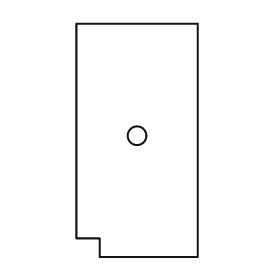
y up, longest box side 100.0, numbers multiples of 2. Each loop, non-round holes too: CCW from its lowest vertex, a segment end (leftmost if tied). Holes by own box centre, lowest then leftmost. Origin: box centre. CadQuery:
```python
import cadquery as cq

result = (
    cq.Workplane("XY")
    .moveTo(-16.0, -50.0)
    .lineTo(26.0, -50.0)
    .lineTo(26.0, 50.0)
    .lineTo(-26.0, 50.0)
    .lineTo(-26.0, -42.0)
    .lineTo(-16.0, -42.0)
    .close()
    .moveTo(0.0, 2.0)
    .circle(4.0)
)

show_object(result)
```